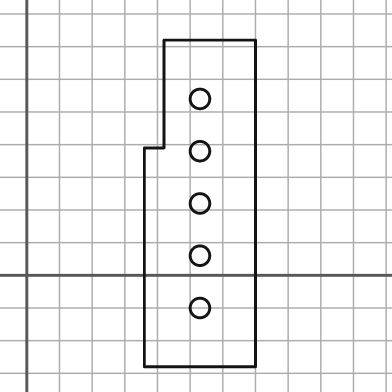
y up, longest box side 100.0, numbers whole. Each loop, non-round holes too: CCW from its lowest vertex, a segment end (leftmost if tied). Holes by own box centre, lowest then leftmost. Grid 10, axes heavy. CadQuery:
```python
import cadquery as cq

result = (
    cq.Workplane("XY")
    .moveTo(36.0, -28.0)
    .lineTo(70.0, -28.0)
    .lineTo(70.0, 72.0)
    .lineTo(42.0, 72.0)
    .lineTo(42.0, 39.0)
    .lineTo(36.0, 39.0)
    .close()
    .moveTo(53.0, -10.0)
    .circle(3.0)
    .moveTo(53.0, 6.0)
    .circle(3.0)
    .moveTo(53.0, 22.0)
    .circle(3.0)
    .moveTo(53.0, 38.0)
    .circle(3.0)
    .moveTo(53.0, 54.0)
    .circle(3.0)
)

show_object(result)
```